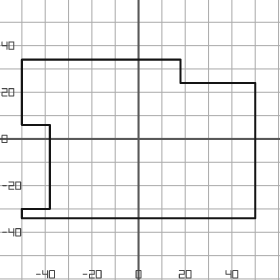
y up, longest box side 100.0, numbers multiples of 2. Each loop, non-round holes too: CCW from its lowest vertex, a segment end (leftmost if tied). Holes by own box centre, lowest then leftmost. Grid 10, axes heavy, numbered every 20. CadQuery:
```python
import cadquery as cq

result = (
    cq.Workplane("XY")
    .moveTo(-50.0, -34.0)
    .lineTo(50.0, -34.0)
    .lineTo(50.0, 24.0)
    .lineTo(18.0, 24.0)
    .lineTo(18.0, 34.0)
    .lineTo(-50.0, 34.0)
    .lineTo(-50.0, 6.0)
    .lineTo(-38.0, 6.0)
    .lineTo(-38.0, -30.0)
    .lineTo(-50.0, -30.0)
    .close()
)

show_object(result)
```